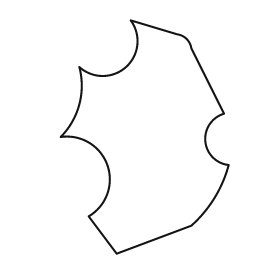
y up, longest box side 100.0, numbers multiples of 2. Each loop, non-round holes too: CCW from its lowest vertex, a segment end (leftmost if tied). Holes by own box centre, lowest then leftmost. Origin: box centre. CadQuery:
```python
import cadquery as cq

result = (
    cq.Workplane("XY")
    .moveTo(-12.0, -50.0)
    .lineTo(20.0, -38.0)
    .threePointArc((30.0, -26.0), (36.0, -12.0))
    .threePointArc((26.0, -2.0), (34.0, 10.0))
    .lineTo(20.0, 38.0)
    .threePointArc((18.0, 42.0), (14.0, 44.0))
    .lineTo(-6.0, 50.0)
    .threePointArc((-8.0, 30.0), (-28.0, 30.0))
    .threePointArc((-28.0, 14.0), (-36.0, 0.0))
    .threePointArc((-16.0, -12.0), (-24.0, -34.0))
    .close()
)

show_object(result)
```